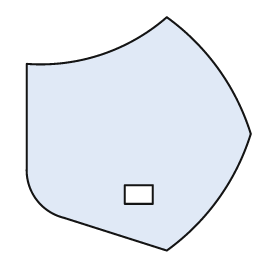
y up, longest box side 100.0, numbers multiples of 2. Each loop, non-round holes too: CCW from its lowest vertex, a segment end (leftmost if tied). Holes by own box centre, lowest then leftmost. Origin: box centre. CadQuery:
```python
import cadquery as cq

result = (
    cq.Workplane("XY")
    .moveTo(12.0, -50.0)
    .threePointArc((34.0, -28.0), (48.0, 0.0))
    .threePointArc((34.0, 28.0), (12.0, 50.0))
    .threePointArc((-16.0, 34.0), (-48.0, 30.0))
    .lineTo(-48.0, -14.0)
    .threePointArc((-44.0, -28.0), (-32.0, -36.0))
    .close()
    .moveTo(-6.0, -30.0)
    .lineTo(6.0, -30.0)
    .lineTo(6.0, -22.0)
    .lineTo(-6.0, -22.0)
    .close()
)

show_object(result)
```